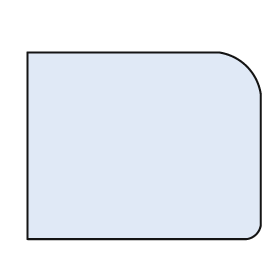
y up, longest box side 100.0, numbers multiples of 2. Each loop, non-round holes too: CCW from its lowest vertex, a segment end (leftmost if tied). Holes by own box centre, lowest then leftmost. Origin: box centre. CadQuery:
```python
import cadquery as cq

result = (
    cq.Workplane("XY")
    .moveTo(-50.0, -40.0)
    .lineTo(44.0, -40.0)
    .threePointArc((48.0, -38.0), (50.0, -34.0))
    .lineTo(50.0, 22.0)
    .threePointArc((44.0, 34.0), (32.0, 40.0))
    .lineTo(-50.0, 40.0)
    .close()
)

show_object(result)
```